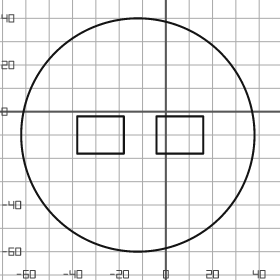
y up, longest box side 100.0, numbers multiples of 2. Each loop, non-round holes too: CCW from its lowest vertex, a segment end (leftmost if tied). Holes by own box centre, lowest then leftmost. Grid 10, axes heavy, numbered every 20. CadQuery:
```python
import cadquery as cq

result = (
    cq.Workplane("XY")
    .moveTo(-12.0, -10.0)
    .circle(50.0)
    .moveTo(-38.0, -18.0)
    .lineTo(-18.0, -18.0)
    .lineTo(-18.0, -2.0)
    .lineTo(-38.0, -2.0)
    .close()
    .moveTo(-4.0, -18.0)
    .lineTo(16.0, -18.0)
    .lineTo(16.0, -2.0)
    .lineTo(-4.0, -2.0)
    .close()
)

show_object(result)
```